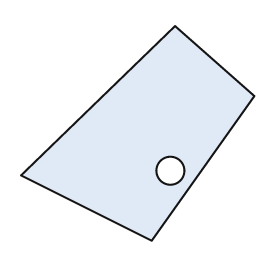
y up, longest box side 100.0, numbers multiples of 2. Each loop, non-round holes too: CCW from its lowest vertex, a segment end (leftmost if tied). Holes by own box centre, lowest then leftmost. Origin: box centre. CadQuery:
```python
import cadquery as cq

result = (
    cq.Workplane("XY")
    .moveTo(6.0, -46.0)
    .lineTo(50.0, 16.0)
    .lineTo(16.0, 46.0)
    .lineTo(-50.0, -18.0)
    .close()
    .moveTo(14.0, -16.0)
    .circle(6.0)
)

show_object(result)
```